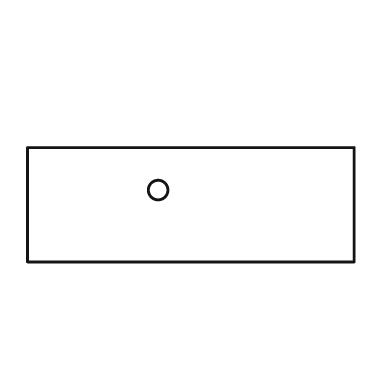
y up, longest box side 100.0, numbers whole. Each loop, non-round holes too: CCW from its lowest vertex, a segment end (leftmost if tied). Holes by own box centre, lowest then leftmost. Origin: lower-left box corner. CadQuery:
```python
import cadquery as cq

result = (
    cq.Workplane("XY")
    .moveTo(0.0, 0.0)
    .lineTo(100.0, 0.0)
    .lineTo(100.0, 35.0)
    .lineTo(0.0, 35.0)
    .close()
    .moveTo(40.0, 22.0)
    .circle(3.0)
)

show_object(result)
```